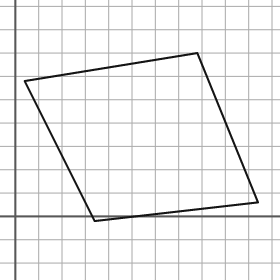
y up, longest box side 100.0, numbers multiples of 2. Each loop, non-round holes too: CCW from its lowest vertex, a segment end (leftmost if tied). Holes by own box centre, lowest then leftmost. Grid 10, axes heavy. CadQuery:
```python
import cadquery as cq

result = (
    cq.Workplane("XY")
    .moveTo(34.0, -2.0)
    .lineTo(104.0, 6.0)
    .lineTo(78.0, 70.0)
    .lineTo(4.0, 58.0)
    .close()
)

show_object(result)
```